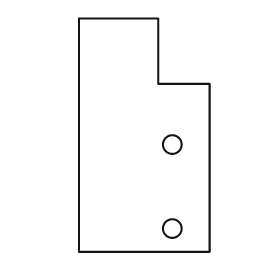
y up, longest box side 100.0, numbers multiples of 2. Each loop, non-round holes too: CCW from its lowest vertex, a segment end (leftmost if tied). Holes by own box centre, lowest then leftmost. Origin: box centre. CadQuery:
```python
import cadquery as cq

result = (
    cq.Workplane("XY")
    .moveTo(-28.0, -50.0)
    .lineTo(28.0, -50.0)
    .lineTo(28.0, 22.0)
    .lineTo(6.0, 22.0)
    .lineTo(6.0, 50.0)
    .lineTo(-28.0, 50.0)
    .close()
    .moveTo(12.0, -40.0)
    .circle(4.0)
    .moveTo(12.0, -4.0)
    .circle(4.0)
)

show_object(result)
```